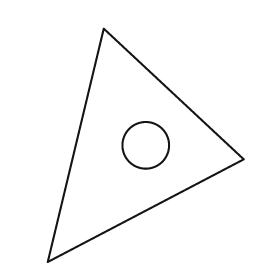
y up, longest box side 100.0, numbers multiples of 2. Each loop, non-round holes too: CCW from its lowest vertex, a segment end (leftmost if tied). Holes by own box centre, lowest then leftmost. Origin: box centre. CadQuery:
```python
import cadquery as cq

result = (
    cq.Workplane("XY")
    .moveTo(-42.0, -50.0)
    .lineTo(42.0, -6.0)
    .lineTo(-18.0, 50.0)
    .close()
    .moveTo(0.0, 0.0)
    .circle(10.0)
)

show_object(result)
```